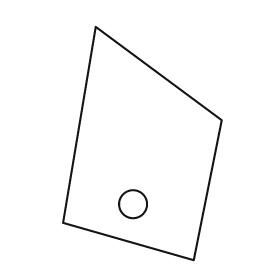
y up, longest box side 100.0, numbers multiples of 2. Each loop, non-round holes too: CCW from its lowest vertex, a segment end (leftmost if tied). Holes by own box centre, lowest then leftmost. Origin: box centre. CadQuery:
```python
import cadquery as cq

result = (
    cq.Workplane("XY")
    .moveTo(22.0, -50.0)
    .lineTo(34.0, 10.0)
    .lineTo(-20.0, 50.0)
    .lineTo(-34.0, -34.0)
    .close()
    .moveTo(-4.0, -26.0)
    .circle(6.0)
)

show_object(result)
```